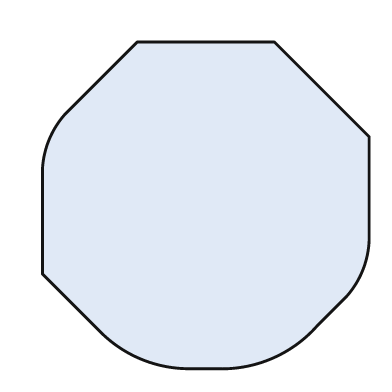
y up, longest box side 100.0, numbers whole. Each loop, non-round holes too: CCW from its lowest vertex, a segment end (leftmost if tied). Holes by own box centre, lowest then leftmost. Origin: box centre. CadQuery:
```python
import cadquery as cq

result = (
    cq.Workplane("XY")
    .moveTo(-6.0, -50.0)
    .lineTo(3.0, -50.0)
    .threePointArc((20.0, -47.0), (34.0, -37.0))
    .lineTo(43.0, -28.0)
    .threePointArc((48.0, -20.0), (50.0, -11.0))
    .lineTo(50.0, 21.0)
    .lineTo(21.0, 50.0)
    .lineTo(-21.0, 50.0)
    .lineTo(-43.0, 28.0)
    .threePointArc((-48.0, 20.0), (-50.0, 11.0))
    .lineTo(-50.0, -21.0)
    .lineTo(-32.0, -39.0)
    .threePointArc((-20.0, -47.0), (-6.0, -50.0))
    .close()
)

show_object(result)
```